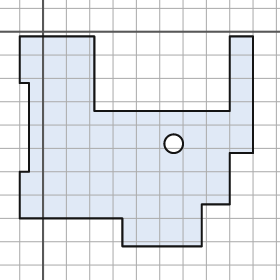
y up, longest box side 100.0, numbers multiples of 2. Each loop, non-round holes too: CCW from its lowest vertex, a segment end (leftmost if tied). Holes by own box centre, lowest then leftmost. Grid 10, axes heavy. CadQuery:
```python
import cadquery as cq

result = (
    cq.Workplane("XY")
    .moveTo(34.0, -92.0)
    .lineTo(68.0, -92.0)
    .lineTo(68.0, -74.0)
    .lineTo(80.0, -74.0)
    .lineTo(80.0, -52.0)
    .lineTo(90.0, -52.0)
    .lineTo(90.0, -2.0)
    .lineTo(80.0, -2.0)
    .lineTo(80.0, -34.0)
    .lineTo(22.0, -34.0)
    .lineTo(22.0, -2.0)
    .lineTo(-10.0, -2.0)
    .lineTo(-10.0, -22.0)
    .lineTo(-6.0, -22.0)
    .lineTo(-6.0, -60.0)
    .lineTo(-10.0, -60.0)
    .lineTo(-10.0, -80.0)
    .lineTo(34.0, -80.0)
    .close()
    .moveTo(56.0, -48.0)
    .circle(4.0)
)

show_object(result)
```